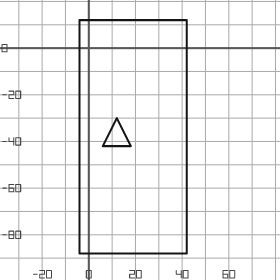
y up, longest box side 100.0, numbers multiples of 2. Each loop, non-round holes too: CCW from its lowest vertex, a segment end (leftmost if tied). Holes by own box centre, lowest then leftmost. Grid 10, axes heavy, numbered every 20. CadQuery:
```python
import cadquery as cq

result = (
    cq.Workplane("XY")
    .moveTo(-4.0, -88.0)
    .lineTo(42.0, -88.0)
    .lineTo(42.0, 12.0)
    .lineTo(-4.0, 12.0)
    .close()
    .moveTo(6.0, -42.0)
    .lineTo(18.0, -42.0)
    .lineTo(12.0, -30.0)
    .close()
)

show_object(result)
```